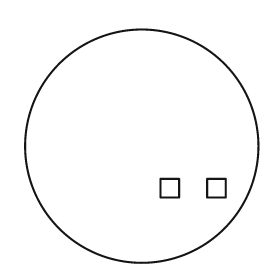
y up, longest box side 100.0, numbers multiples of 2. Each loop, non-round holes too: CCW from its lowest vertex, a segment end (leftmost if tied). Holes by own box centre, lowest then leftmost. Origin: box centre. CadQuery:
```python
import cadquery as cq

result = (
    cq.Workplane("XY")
    .moveTo(0.0, 0.0)
    .circle(50.0)
    .moveTo(8.0, -22.0)
    .lineTo(16.0, -22.0)
    .lineTo(16.0, -14.0)
    .lineTo(8.0, -14.0)
    .close()
    .moveTo(28.0, -22.0)
    .lineTo(36.0, -22.0)
    .lineTo(36.0, -14.0)
    .lineTo(28.0, -14.0)
    .close()
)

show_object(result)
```